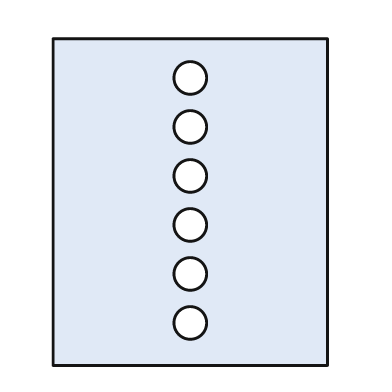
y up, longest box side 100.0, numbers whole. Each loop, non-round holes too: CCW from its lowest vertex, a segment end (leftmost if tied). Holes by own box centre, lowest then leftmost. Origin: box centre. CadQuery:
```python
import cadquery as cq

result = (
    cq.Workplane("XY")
    .moveTo(-42.0, -50.0)
    .lineTo(42.0, -50.0)
    .lineTo(42.0, 50.0)
    .lineTo(-42.0, 50.0)
    .close()
    .moveTo(0.0, -37.0)
    .circle(5.0)
    .moveTo(0.0, -22.0)
    .circle(5.0)
    .moveTo(0.0, -7.0)
    .circle(5.0)
    .moveTo(0.0, 8.0)
    .circle(5.0)
    .moveTo(0.0, 23.0)
    .circle(5.0)
    .moveTo(0.0, 38.0)
    .circle(5.0)
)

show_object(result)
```